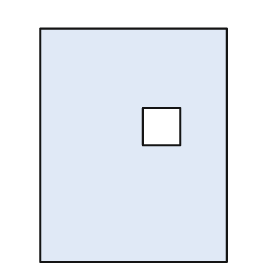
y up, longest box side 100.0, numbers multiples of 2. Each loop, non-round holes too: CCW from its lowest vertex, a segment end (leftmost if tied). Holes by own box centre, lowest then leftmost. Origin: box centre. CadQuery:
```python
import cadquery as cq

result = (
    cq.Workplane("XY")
    .moveTo(-40.0, -50.0)
    .lineTo(40.0, -50.0)
    .lineTo(40.0, 50.0)
    .lineTo(-40.0, 50.0)
    .close()
    .moveTo(4.0, 0.0)
    .lineTo(20.0, 0.0)
    .lineTo(20.0, 16.0)
    .lineTo(4.0, 16.0)
    .close()
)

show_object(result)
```